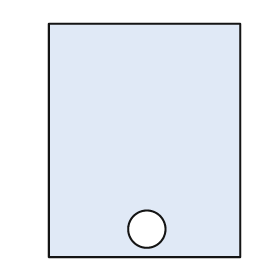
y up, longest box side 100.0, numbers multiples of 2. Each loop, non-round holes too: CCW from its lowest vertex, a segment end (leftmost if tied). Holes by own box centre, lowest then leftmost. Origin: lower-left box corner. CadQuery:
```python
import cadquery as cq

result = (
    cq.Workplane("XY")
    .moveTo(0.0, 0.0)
    .lineTo(82.0, 0.0)
    .lineTo(82.0, 100.0)
    .lineTo(0.0, 100.0)
    .close()
    .moveTo(42.0, 12.0)
    .circle(8.0)
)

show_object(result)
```